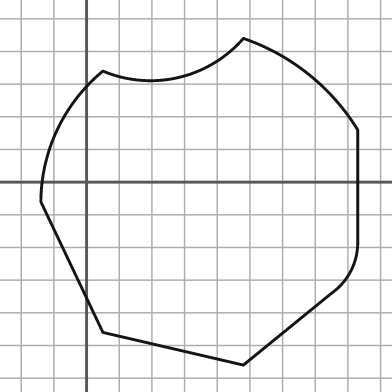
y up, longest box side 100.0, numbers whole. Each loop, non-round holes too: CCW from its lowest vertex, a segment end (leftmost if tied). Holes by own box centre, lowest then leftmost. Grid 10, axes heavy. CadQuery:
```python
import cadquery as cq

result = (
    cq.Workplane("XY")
    .moveTo(48.0, -56.0)
    .lineTo(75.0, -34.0)
    .threePointArc((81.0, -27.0), (83.0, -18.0))
    .lineTo(83.0, 16.0)
    .threePointArc((68.0, 33.0), (48.0, 44.0))
    .threePointArc((28.0, 32.0), (5.0, 34.0))
    .threePointArc((-9.0, 16.0), (-14.0, -6.0))
    .lineTo(5.0, -46.0)
    .close()
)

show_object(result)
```